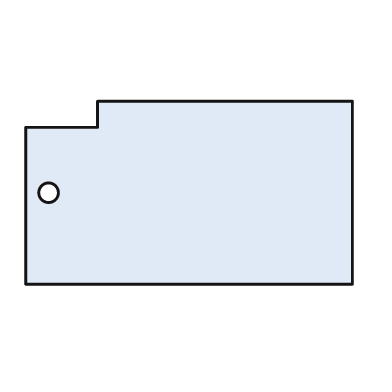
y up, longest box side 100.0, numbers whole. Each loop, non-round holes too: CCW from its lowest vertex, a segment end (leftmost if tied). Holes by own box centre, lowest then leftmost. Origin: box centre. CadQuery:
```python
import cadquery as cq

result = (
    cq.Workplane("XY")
    .moveTo(-50.0, -28.0)
    .lineTo(50.0, -28.0)
    .lineTo(50.0, 28.0)
    .lineTo(-28.0, 28.0)
    .lineTo(-28.0, 20.0)
    .lineTo(-50.0, 20.0)
    .close()
    .moveTo(-43.0, 0.0)
    .circle(3.0)
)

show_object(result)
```